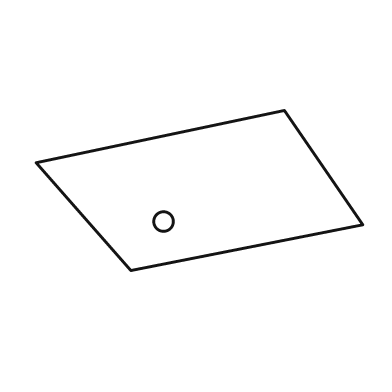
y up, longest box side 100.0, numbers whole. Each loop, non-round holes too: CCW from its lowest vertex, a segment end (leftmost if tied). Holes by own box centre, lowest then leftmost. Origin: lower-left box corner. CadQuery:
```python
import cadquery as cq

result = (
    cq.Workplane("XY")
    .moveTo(29.0, 0.0)
    .lineTo(100.0, 14.0)
    .lineTo(76.0, 49.0)
    .lineTo(0.0, 33.0)
    .close()
    .moveTo(39.0, 15.0)
    .circle(3.0)
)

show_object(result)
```